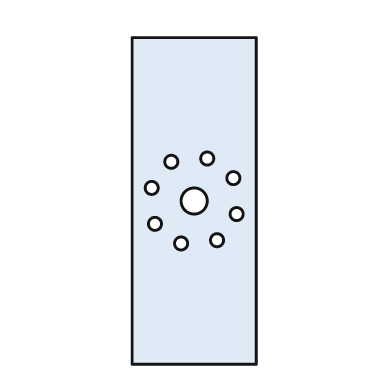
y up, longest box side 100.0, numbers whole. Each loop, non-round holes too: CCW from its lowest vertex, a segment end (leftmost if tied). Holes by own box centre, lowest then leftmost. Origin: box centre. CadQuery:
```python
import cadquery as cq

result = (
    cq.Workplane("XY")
    .moveTo(-19.0, -50.0)
    .lineTo(19.0, -50.0)
    .lineTo(19.0, 50.0)
    .lineTo(-19.0, 50.0)
    .close()
    .moveTo(-4.0, -13.0)
    .circle(2.0)
    .moveTo(7.0, -12.0)
    .circle(2.0)
    .moveTo(-12.0, -7.0)
    .circle(2.0)
    .moveTo(13.0, -4.0)
    .circle(2.0)
    .moveTo(0.0, 0.0)
    .circle(4.0)
    .moveTo(-13.0, 4.0)
    .circle(2.0)
    .moveTo(12.0, 7.0)
    .circle(2.0)
    .moveTo(-7.0, 12.0)
    .circle(2.0)
    .moveTo(4.0, 13.0)
    .circle(2.0)
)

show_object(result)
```